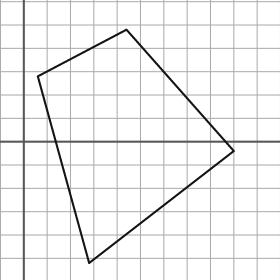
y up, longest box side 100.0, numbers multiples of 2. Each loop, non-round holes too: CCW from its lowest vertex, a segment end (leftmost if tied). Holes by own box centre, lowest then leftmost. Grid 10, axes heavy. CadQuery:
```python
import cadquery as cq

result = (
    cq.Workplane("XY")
    .moveTo(28.0, -52.0)
    .lineTo(90.0, -4.0)
    .lineTo(44.0, 48.0)
    .lineTo(6.0, 28.0)
    .close()
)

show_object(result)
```